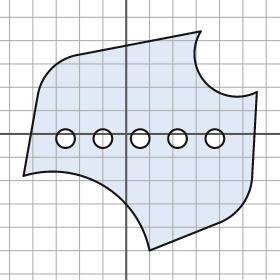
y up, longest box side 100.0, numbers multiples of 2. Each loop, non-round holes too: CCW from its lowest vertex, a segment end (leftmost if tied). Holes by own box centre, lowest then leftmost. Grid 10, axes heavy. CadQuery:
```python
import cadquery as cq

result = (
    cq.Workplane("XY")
    .moveTo(10.0, -50.0)
    .lineTo(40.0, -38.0)
    .threePointArc((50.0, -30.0), (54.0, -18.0))
    .lineTo(56.0, 18.0)
    .threePointArc((34.0, 22.0), (32.0, 44.0))
    .lineTo(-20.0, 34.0)
    .threePointArc((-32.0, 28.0), (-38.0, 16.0))
    .lineTo(-44.0, -18.0)
    .threePointArc((-10.0, -22.0), (10.0, -50.0))
    .close()
    .moveTo(-26.0, -2.0)
    .circle(4.0)
    .moveTo(-10.0, -2.0)
    .circle(4.0)
    .moveTo(6.0, -2.0)
    .circle(4.0)
    .moveTo(22.0, -2.0)
    .circle(4.0)
    .moveTo(38.0, -2.0)
    .circle(4.0)
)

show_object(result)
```